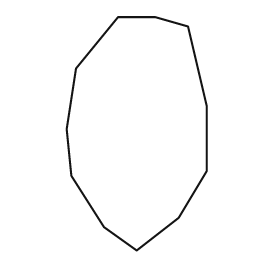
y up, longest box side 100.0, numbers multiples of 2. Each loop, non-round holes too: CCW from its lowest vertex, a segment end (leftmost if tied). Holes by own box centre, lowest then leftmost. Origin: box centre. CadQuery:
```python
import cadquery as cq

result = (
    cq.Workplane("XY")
    .moveTo(0.0, -50.0)
    .lineTo(18.0, -36.0)
    .lineTo(30.0, -16.0)
    .lineTo(30.0, 12.0)
    .lineTo(22.0, 46.0)
    .lineTo(8.0, 50.0)
    .lineTo(-8.0, 50.0)
    .lineTo(-26.0, 28.0)
    .lineTo(-30.0, 2.0)
    .lineTo(-28.0, -18.0)
    .lineTo(-14.0, -40.0)
    .close()
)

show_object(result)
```